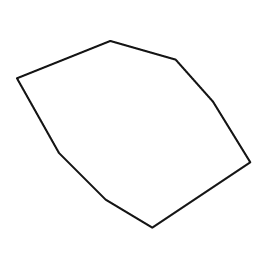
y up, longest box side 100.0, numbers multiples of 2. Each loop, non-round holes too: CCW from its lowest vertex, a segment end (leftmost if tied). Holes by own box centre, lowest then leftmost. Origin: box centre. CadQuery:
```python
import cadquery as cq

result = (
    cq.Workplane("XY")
    .moveTo(8.0, -40.0)
    .lineTo(50.0, -12.0)
    .lineTo(34.0, 14.0)
    .lineTo(18.0, 32.0)
    .lineTo(-10.0, 40.0)
    .lineTo(-50.0, 24.0)
    .lineTo(-32.0, -8.0)
    .lineTo(-12.0, -28.0)
    .close()
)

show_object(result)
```